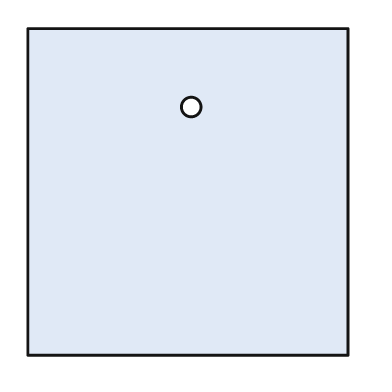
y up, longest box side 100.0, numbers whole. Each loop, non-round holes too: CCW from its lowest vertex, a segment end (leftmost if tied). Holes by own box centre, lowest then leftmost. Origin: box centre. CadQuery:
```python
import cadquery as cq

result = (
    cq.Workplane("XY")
    .moveTo(-49.0, -50.0)
    .lineTo(49.0, -50.0)
    .lineTo(49.0, 50.0)
    .lineTo(-49.0, 50.0)
    .close()
    .moveTo(1.0, 26.0)
    .circle(3.0)
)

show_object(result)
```